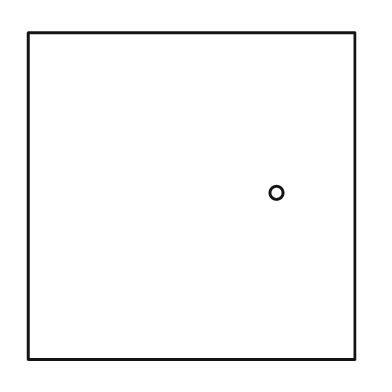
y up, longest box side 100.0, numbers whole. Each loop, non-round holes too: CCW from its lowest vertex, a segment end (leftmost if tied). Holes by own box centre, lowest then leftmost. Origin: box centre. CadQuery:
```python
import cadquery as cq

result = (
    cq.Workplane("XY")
    .moveTo(-50.0, -50.0)
    .lineTo(50.0, -50.0)
    .lineTo(50.0, 50.0)
    .lineTo(-50.0, 50.0)
    .close()
    .moveTo(26.0, 1.0)
    .circle(2.0)
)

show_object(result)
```